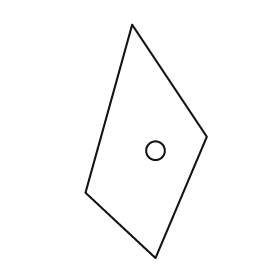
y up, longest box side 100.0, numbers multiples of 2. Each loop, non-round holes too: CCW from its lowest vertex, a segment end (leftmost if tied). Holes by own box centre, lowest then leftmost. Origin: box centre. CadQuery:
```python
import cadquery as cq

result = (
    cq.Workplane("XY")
    .moveTo(4.0, -50.0)
    .lineTo(26.0, 2.0)
    .lineTo(-6.0, 50.0)
    .lineTo(-26.0, -22.0)
    .close()
    .moveTo(4.0, -4.0)
    .circle(4.0)
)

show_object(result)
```